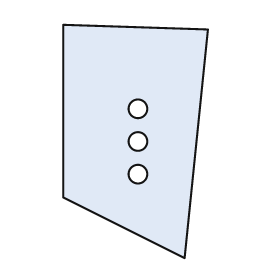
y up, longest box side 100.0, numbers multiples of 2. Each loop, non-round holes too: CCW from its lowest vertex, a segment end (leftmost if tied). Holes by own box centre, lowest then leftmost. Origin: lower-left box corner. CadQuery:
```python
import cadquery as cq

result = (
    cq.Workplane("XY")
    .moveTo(52.0, 0.0)
    .lineTo(62.0, 98.0)
    .lineTo(0.0, 100.0)
    .lineTo(0.0, 26.0)
    .close()
    .moveTo(32.0, 36.0)
    .circle(4.0)
    .moveTo(32.0, 50.0)
    .circle(4.0)
    .moveTo(32.0, 64.0)
    .circle(4.0)
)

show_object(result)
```